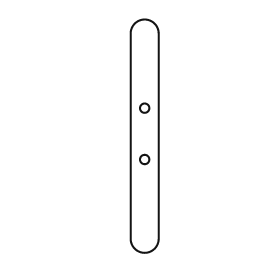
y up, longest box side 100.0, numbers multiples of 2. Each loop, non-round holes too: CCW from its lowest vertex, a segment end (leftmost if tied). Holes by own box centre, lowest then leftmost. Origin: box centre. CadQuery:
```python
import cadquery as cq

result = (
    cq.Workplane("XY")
    .moveTo(-6.0, -44.0)
    .threePointArc((0.0, -50.0), (6.0, -44.0))
    .lineTo(6.0, 44.0)
    .threePointArc((0.0, 50.0), (-6.0, 44.0))
    .close()
    .moveTo(0.0, -10.0)
    .circle(2.0)
    .moveTo(0.0, 12.0)
    .circle(2.0)
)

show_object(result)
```